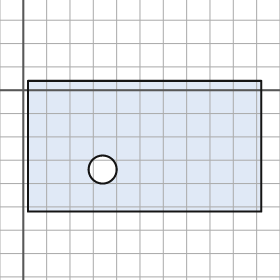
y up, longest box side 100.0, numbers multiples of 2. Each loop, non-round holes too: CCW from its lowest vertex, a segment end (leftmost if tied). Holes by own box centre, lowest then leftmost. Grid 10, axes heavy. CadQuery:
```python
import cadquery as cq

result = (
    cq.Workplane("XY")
    .moveTo(2.0, -52.0)
    .lineTo(102.0, -52.0)
    .lineTo(102.0, 4.0)
    .lineTo(2.0, 4.0)
    .close()
    .moveTo(34.0, -34.0)
    .circle(6.0)
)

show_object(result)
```